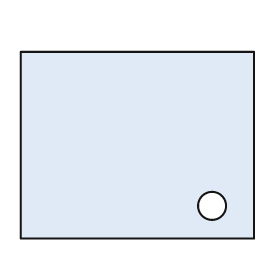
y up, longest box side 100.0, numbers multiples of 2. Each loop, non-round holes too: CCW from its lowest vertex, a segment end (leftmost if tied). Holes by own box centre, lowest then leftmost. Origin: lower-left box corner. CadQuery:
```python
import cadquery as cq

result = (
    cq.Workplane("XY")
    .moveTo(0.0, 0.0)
    .lineTo(100.0, 0.0)
    .lineTo(100.0, 80.0)
    .lineTo(0.0, 80.0)
    .close()
    .moveTo(82.0, 14.0)
    .circle(6.0)
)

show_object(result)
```